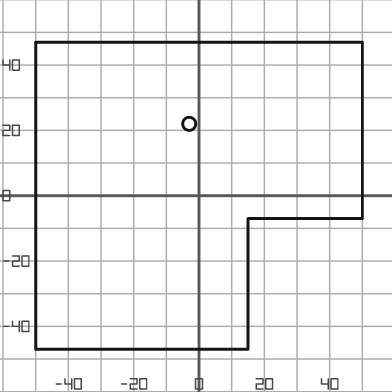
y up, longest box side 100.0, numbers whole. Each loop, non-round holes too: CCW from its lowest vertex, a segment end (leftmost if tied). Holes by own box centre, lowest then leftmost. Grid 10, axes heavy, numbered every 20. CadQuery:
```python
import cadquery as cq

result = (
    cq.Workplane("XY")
    .moveTo(-50.0, -47.0)
    .lineTo(15.0, -47.0)
    .lineTo(15.0, -7.0)
    .lineTo(50.0, -7.0)
    .lineTo(50.0, 47.0)
    .lineTo(-50.0, 47.0)
    .close()
    .moveTo(-3.0, 22.0)
    .circle(2.0)
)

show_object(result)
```